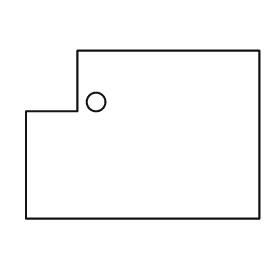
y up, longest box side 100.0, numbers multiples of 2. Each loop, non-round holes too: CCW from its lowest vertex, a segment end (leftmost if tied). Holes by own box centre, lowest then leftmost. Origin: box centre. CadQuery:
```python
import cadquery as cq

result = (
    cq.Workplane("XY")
    .moveTo(-50.0, -36.0)
    .lineTo(50.0, -36.0)
    .lineTo(50.0, 36.0)
    .lineTo(-28.0, 36.0)
    .lineTo(-28.0, 10.0)
    .lineTo(-50.0, 10.0)
    .close()
    .moveTo(-20.0, 14.0)
    .circle(4.0)
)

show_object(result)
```